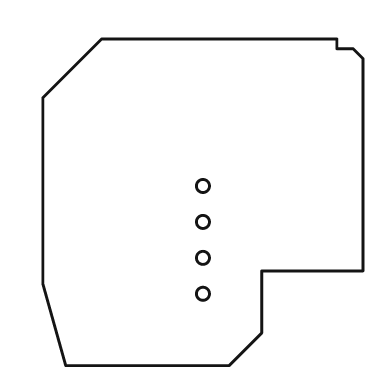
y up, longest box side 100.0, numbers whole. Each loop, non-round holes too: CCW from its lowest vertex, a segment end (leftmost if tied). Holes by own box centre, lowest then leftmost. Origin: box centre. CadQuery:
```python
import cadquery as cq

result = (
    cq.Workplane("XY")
    .moveTo(-42.0, -50.0)
    .lineTo(8.0, -50.0)
    .lineTo(18.0, -40.0)
    .lineTo(18.0, -21.0)
    .lineTo(49.0, -21.0)
    .lineTo(49.0, 44.0)
    .lineTo(46.0, 47.0)
    .lineTo(41.0, 47.0)
    .lineTo(41.0, 50.0)
    .lineTo(-31.0, 50.0)
    .lineTo(-49.0, 32.0)
    .lineTo(-49.0, -25.0)
    .close()
    .moveTo(0.0, -28.0)
    .circle(2.0)
    .moveTo(0.0, -17.0)
    .circle(2.0)
    .moveTo(0.0, -6.0)
    .circle(2.0)
    .moveTo(0.0, 5.0)
    .circle(2.0)
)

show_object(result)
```